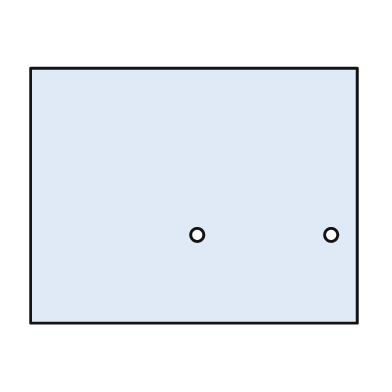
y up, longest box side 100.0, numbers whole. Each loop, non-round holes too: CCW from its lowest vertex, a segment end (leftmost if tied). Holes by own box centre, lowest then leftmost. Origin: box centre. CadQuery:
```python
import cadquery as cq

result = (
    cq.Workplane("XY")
    .moveTo(-50.0, -39.0)
    .lineTo(50.0, -39.0)
    .lineTo(50.0, 39.0)
    .lineTo(-50.0, 39.0)
    .close()
    .moveTo(1.0, -12.0)
    .circle(2.0)
    .moveTo(42.0, -12.0)
    .circle(2.0)
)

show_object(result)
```